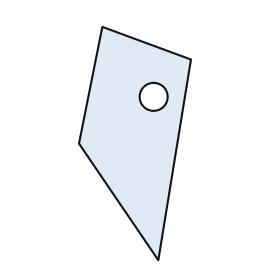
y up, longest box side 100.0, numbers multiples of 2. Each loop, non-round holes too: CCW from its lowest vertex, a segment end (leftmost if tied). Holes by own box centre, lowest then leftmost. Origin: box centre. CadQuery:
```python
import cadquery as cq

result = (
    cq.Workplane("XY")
    .moveTo(10.0, -50.0)
    .lineTo(24.0, 36.0)
    .lineTo(-14.0, 50.0)
    .lineTo(-24.0, 0.0)
    .close()
    .moveTo(8.0, 20.0)
    .circle(6.0)
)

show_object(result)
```